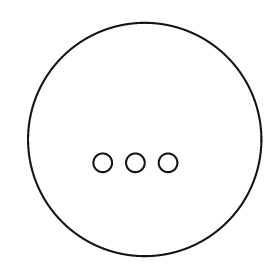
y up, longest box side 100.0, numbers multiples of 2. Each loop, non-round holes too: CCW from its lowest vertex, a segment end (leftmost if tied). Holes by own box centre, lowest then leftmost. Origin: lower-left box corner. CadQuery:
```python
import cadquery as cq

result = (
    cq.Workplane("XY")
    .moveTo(50.0, 50.0)
    .circle(50.0)
    .moveTo(32.0, 40.0)
    .circle(4.0)
    .moveTo(46.0, 40.0)
    .circle(4.0)
    .moveTo(60.0, 40.0)
    .circle(4.0)
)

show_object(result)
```